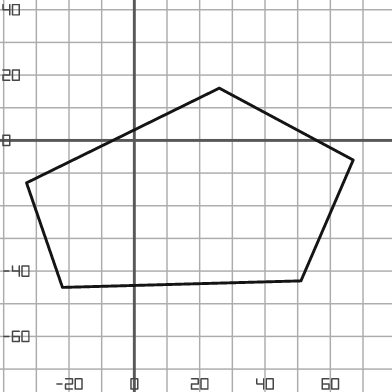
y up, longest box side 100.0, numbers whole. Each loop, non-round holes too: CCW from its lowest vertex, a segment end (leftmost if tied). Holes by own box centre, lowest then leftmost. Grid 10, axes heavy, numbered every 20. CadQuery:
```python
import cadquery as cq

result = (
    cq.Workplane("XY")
    .moveTo(-22.0, -45.0)
    .lineTo(51.0, -43.0)
    .lineTo(67.0, -6.0)
    .lineTo(26.0, 16.0)
    .lineTo(-33.0, -13.0)
    .close()
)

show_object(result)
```